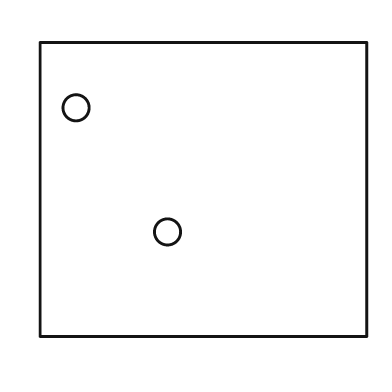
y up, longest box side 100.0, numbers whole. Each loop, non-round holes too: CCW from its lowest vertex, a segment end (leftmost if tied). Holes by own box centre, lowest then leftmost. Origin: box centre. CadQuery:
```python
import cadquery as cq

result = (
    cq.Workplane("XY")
    .moveTo(-50.0, -45.0)
    .lineTo(50.0, -45.0)
    .lineTo(50.0, 45.0)
    .lineTo(-50.0, 45.0)
    .close()
    .moveTo(-11.0, -13.0)
    .circle(4.0)
    .moveTo(-39.0, 25.0)
    .circle(4.0)
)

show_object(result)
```